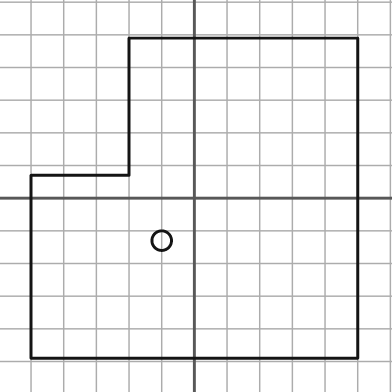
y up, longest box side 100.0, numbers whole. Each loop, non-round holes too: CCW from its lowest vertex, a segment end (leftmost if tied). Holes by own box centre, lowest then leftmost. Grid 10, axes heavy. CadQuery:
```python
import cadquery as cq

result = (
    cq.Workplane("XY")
    .moveTo(-50.0, -49.0)
    .lineTo(50.0, -49.0)
    .lineTo(50.0, 49.0)
    .lineTo(-20.0, 49.0)
    .lineTo(-20.0, 7.0)
    .lineTo(-50.0, 7.0)
    .close()
    .moveTo(-10.0, -13.0)
    .circle(3.0)
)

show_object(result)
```